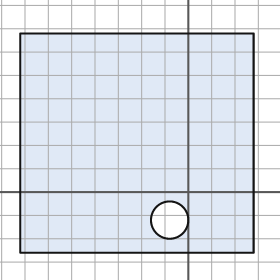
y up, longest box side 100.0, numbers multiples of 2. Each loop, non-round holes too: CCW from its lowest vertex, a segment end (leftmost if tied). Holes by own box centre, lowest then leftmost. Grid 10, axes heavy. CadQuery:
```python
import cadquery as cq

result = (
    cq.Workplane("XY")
    .moveTo(-72.0, -26.0)
    .lineTo(28.0, -26.0)
    .lineTo(28.0, 68.0)
    .lineTo(-72.0, 68.0)
    .close()
    .moveTo(-8.0, -12.0)
    .circle(8.0)
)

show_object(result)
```